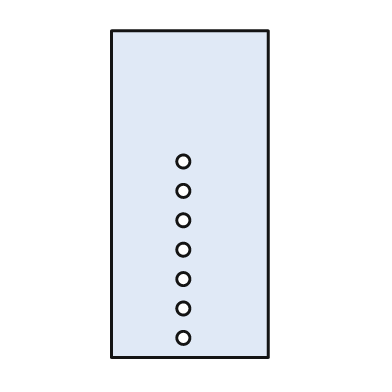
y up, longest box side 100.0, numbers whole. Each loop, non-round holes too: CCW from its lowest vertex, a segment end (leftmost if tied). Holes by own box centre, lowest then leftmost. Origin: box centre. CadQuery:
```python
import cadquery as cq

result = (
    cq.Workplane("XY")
    .moveTo(-24.0, -50.0)
    .lineTo(24.0, -50.0)
    .lineTo(24.0, 50.0)
    .lineTo(-24.0, 50.0)
    .close()
    .moveTo(-2.0, -44.0)
    .circle(2.0)
    .moveTo(-2.0, -35.0)
    .circle(2.0)
    .moveTo(-2.0, -26.0)
    .circle(2.0)
    .moveTo(-2.0, -17.0)
    .circle(2.0)
    .moveTo(-2.0, -8.0)
    .circle(2.0)
    .moveTo(-2.0, 1.0)
    .circle(2.0)
    .moveTo(-2.0, 10.0)
    .circle(2.0)
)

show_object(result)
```